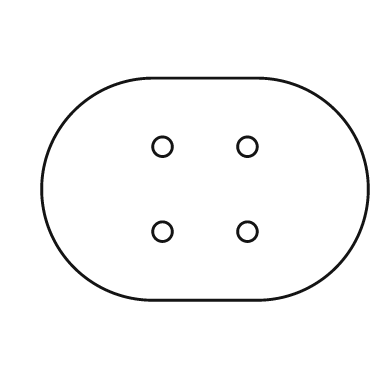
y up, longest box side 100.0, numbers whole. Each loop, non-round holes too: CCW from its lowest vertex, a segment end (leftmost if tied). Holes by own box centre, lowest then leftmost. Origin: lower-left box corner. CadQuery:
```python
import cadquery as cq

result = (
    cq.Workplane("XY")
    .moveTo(34.0, 0.0)
    .lineTo(66.0, 0.0)
    .threePointArc((100.0, 34.0), (66.0, 68.0))
    .lineTo(34.0, 68.0)
    .threePointArc((0.0, 34.0), (34.0, 0.0))
    .close()
    .moveTo(37.0, 21.0)
    .circle(3.0)
    .moveTo(63.0, 21.0)
    .circle(3.0)
    .moveTo(37.0, 47.0)
    .circle(3.0)
    .moveTo(63.0, 47.0)
    .circle(3.0)
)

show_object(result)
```